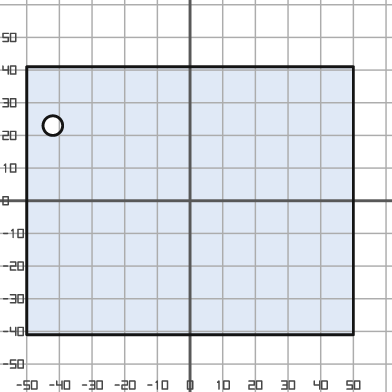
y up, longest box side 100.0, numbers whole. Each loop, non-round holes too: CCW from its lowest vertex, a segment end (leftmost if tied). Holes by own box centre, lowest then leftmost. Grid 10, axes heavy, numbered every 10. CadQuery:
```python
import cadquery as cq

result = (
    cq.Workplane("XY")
    .moveTo(-50.0, -41.0)
    .lineTo(50.0, -41.0)
    .lineTo(50.0, 41.0)
    .lineTo(-50.0, 41.0)
    .close()
    .moveTo(-42.0, 23.0)
    .circle(3.0)
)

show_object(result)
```